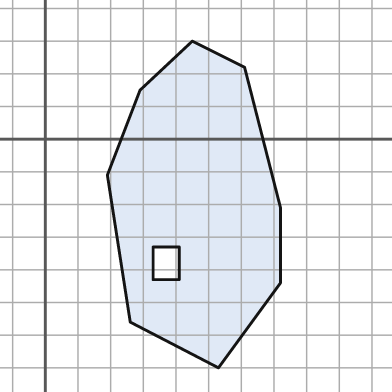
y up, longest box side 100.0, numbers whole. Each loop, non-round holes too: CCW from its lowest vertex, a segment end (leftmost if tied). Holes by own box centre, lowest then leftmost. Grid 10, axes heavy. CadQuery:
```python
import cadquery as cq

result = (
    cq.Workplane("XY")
    .moveTo(53.0, -70.0)
    .lineTo(72.0, -44.0)
    .lineTo(72.0, -21.0)
    .lineTo(61.0, 22.0)
    .lineTo(45.0, 30.0)
    .lineTo(29.0, 15.0)
    .lineTo(19.0, -11.0)
    .lineTo(26.0, -56.0)
    .close()
    .moveTo(33.0, -43.0)
    .lineTo(41.0, -43.0)
    .lineTo(41.0, -33.0)
    .lineTo(33.0, -33.0)
    .close()
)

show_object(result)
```